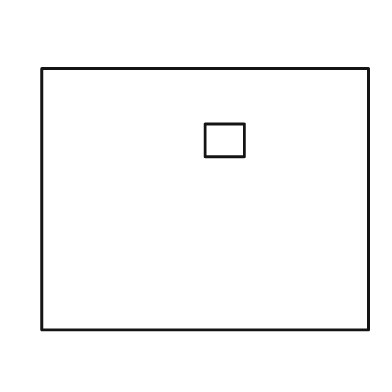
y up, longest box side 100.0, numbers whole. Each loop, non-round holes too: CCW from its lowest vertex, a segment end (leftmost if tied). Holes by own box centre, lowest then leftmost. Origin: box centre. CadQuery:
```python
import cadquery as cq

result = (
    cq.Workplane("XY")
    .moveTo(-50.0, -40.0)
    .lineTo(50.0, -40.0)
    .lineTo(50.0, 40.0)
    .lineTo(-50.0, 40.0)
    .close()
    .moveTo(0.0, 13.0)
    .lineTo(12.0, 13.0)
    .lineTo(12.0, 23.0)
    .lineTo(0.0, 23.0)
    .close()
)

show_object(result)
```